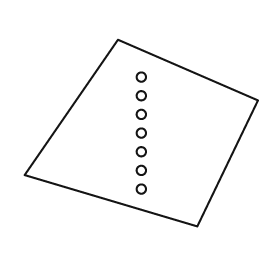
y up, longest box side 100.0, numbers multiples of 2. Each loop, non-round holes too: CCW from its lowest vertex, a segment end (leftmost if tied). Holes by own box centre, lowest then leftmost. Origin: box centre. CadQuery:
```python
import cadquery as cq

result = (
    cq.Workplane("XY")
    .moveTo(24.0, -40.0)
    .lineTo(50.0, 14.0)
    .lineTo(-10.0, 40.0)
    .lineTo(-50.0, -18.0)
    .close()
    .moveTo(0.0, -24.0)
    .circle(2.0)
    .moveTo(0.0, -16.0)
    .circle(2.0)
    .moveTo(0.0, -8.0)
    .circle(2.0)
    .moveTo(0.0, 0.0)
    .circle(2.0)
    .moveTo(0.0, 8.0)
    .circle(2.0)
    .moveTo(0.0, 16.0)
    .circle(2.0)
    .moveTo(0.0, 24.0)
    .circle(2.0)
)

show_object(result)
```